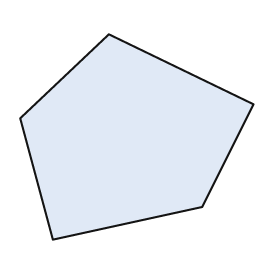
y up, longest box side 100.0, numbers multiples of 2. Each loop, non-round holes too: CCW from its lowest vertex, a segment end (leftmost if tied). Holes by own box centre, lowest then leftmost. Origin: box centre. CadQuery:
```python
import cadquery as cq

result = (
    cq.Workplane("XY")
    .moveTo(-36.0, -44.0)
    .lineTo(28.0, -30.0)
    .lineTo(50.0, 14.0)
    .lineTo(-12.0, 44.0)
    .lineTo(-50.0, 8.0)
    .close()
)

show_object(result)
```